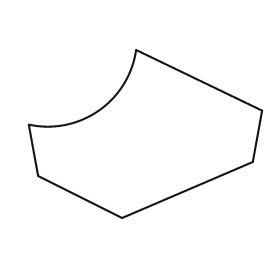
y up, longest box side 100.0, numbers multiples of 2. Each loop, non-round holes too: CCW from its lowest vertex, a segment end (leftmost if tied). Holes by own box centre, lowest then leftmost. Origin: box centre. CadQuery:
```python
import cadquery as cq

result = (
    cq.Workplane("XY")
    .moveTo(-10.0, -36.0)
    .lineTo(46.0, -12.0)
    .lineTo(50.0, 10.0)
    .lineTo(-4.0, 36.0)
    .threePointArc((-20.0, 10.0), (-50.0, 4.0))
    .lineTo(-46.0, -18.0)
    .close()
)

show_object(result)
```